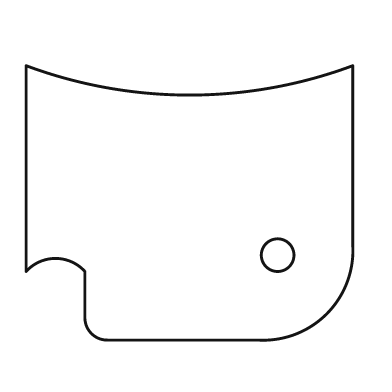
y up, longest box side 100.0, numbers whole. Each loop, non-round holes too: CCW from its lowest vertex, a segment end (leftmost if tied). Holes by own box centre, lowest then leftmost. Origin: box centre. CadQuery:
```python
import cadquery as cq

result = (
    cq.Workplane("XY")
    .moveTo(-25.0, -42.0)
    .lineTo(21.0, -42.0)
    .threePointArc((42.0, -34.0), (50.0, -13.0))
    .lineTo(50.0, 42.0)
    .threePointArc((0.0, 33.0), (-50.0, 42.0))
    .lineTo(-50.0, -21.0)
    .threePointArc((-41.0, -17.0), (-32.0, -21.0))
    .lineTo(-32.0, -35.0)
    .threePointArc((-30.0, -40.0), (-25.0, -42.0))
    .close()
    .moveTo(27.0, -16.0)
    .circle(5.0)
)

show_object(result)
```